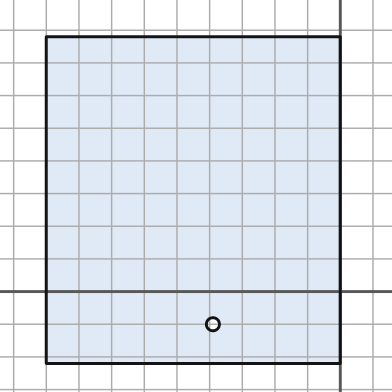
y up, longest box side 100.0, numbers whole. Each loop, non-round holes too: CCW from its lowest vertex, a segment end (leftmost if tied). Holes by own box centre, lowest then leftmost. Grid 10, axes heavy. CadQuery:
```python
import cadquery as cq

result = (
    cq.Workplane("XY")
    .moveTo(-90.0, -22.0)
    .lineTo(0.0, -22.0)
    .lineTo(0.0, 78.0)
    .lineTo(-90.0, 78.0)
    .close()
    .moveTo(-39.0, -10.0)
    .circle(2.0)
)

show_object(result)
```